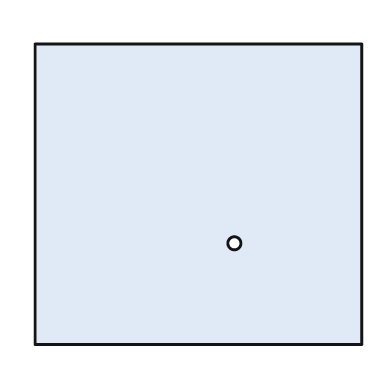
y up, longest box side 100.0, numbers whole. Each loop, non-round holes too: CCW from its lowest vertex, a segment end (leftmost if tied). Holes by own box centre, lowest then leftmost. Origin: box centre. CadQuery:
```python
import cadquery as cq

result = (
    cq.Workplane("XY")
    .moveTo(-50.0, -46.0)
    .lineTo(50.0, -46.0)
    .lineTo(50.0, 46.0)
    .lineTo(-50.0, 46.0)
    .close()
    .moveTo(11.0, -15.0)
    .circle(2.0)
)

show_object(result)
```